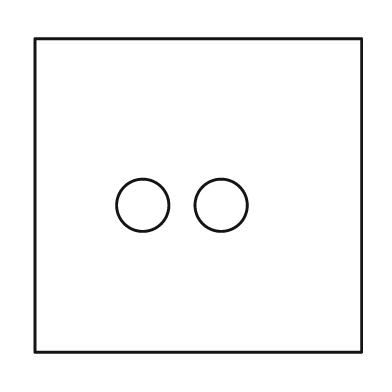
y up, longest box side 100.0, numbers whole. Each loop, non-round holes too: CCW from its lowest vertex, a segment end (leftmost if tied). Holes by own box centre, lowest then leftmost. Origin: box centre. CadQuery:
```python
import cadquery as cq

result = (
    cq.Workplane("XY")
    .moveTo(-50.0, -48.0)
    .lineTo(50.0, -48.0)
    .lineTo(50.0, 48.0)
    .lineTo(-50.0, 48.0)
    .close()
    .moveTo(-17.0, -3.0)
    .circle(8.0)
    .moveTo(7.0, -3.0)
    .circle(8.0)
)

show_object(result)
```